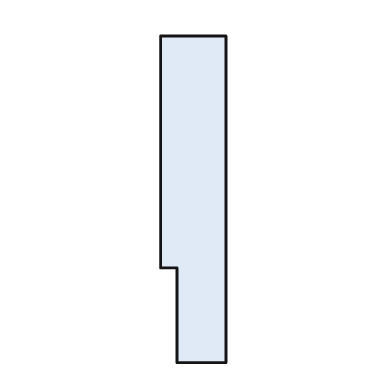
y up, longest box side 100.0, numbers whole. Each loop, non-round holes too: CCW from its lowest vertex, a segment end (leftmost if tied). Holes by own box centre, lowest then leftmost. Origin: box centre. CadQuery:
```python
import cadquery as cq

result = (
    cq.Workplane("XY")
    .moveTo(-5.0, -50.0)
    .lineTo(10.0, -50.0)
    .lineTo(10.0, 50.0)
    .lineTo(-10.0, 50.0)
    .lineTo(-10.0, -21.0)
    .lineTo(-5.0, -21.0)
    .close()
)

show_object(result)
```